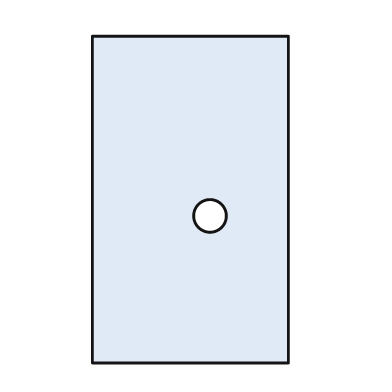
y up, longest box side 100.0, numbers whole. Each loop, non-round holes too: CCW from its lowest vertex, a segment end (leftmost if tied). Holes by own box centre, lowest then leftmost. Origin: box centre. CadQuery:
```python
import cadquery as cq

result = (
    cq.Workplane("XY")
    .moveTo(-30.0, -50.0)
    .lineTo(30.0, -50.0)
    .lineTo(30.0, 50.0)
    .lineTo(-30.0, 50.0)
    .close()
    .moveTo(6.0, -5.0)
    .circle(5.0)
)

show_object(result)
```